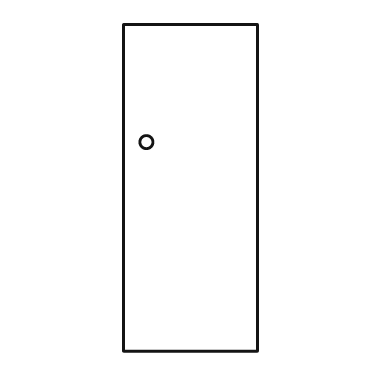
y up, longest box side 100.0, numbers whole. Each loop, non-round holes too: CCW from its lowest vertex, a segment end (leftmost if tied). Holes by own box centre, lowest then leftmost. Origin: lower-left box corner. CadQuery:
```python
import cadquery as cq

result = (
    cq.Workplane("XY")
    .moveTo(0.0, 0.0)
    .lineTo(41.0, 0.0)
    .lineTo(41.0, 100.0)
    .lineTo(0.0, 100.0)
    .close()
    .moveTo(7.0, 64.0)
    .circle(2.0)
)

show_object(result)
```